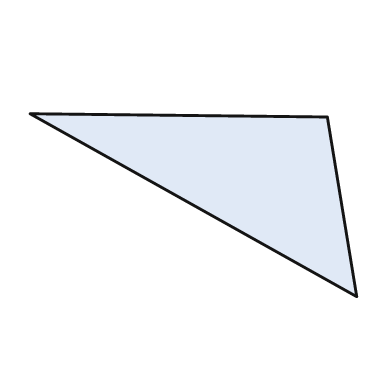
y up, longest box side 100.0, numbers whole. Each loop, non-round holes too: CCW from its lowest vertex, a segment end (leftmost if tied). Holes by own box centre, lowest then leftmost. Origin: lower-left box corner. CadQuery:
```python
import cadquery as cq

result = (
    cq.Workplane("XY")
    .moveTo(100.0, 0.0)
    .lineTo(91.0, 55.0)
    .lineTo(0.0, 56.0)
    .close()
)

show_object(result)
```